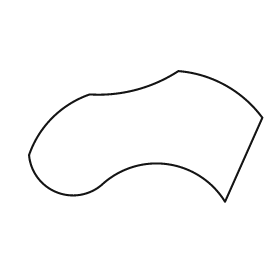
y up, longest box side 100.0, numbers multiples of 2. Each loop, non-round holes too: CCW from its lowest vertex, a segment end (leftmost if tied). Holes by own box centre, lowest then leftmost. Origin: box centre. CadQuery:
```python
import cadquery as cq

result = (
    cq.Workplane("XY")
    .moveTo(34.0, -28.0)
    .lineTo(50.0, 8.0)
    .threePointArc((34.0, 22.0), (14.0, 28.0))
    .threePointArc((-4.0, 20.0), (-24.0, 18.0))
    .threePointArc((-40.0, 8.0), (-50.0, -8.0))
    .threePointArc((-38.0, -24.0), (-18.0, -20.0))
    .threePointArc((10.0, -12.0), (34.0, -28.0))
    .close()
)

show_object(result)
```